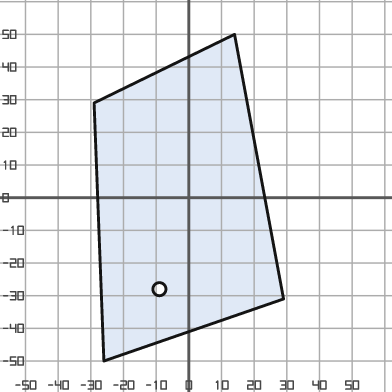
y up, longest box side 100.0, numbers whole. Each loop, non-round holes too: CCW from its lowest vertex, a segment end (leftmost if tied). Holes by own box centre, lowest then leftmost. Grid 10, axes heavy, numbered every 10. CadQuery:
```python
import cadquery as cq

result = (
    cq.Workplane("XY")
    .moveTo(-26.0, -50.0)
    .lineTo(29.0, -31.0)
    .lineTo(14.0, 50.0)
    .lineTo(-29.0, 29.0)
    .close()
    .moveTo(-9.0, -28.0)
    .circle(2.0)
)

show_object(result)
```